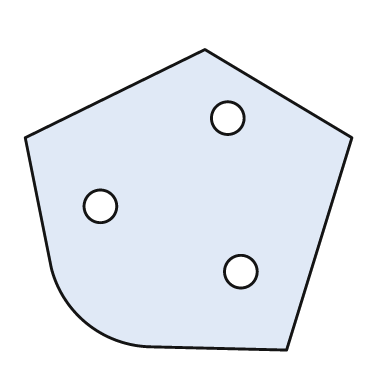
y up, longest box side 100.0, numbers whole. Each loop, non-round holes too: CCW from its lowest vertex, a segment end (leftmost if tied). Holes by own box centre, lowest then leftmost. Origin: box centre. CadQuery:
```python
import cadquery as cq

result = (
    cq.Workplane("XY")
    .moveTo(30.0, -46.0)
    .lineTo(50.0, 19.0)
    .lineTo(5.0, 46.0)
    .lineTo(-50.0, 19.0)
    .lineTo(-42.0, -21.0)
    .threePointArc((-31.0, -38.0), (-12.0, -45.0))
    .close()
    .moveTo(16.0, -22.0)
    .circle(5.0)
    .moveTo(-27.0, -2.0)
    .circle(5.0)
    .moveTo(12.0, 25.0)
    .circle(5.0)
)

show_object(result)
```